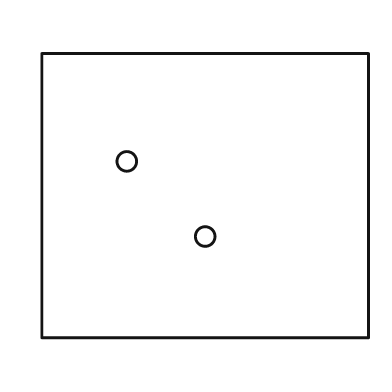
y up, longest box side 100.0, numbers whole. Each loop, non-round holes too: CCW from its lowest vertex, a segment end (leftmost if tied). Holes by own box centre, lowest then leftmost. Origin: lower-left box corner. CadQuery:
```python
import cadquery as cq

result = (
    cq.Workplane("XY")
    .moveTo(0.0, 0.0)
    .lineTo(100.0, 0.0)
    .lineTo(100.0, 87.0)
    .lineTo(0.0, 87.0)
    .close()
    .moveTo(50.0, 31.0)
    .circle(3.0)
    .moveTo(26.0, 54.0)
    .circle(3.0)
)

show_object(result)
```